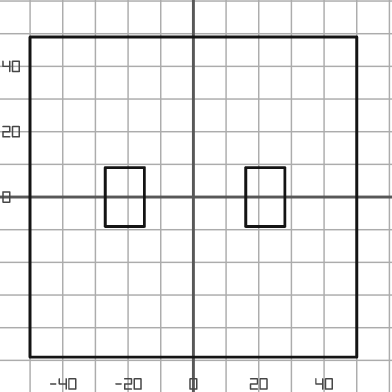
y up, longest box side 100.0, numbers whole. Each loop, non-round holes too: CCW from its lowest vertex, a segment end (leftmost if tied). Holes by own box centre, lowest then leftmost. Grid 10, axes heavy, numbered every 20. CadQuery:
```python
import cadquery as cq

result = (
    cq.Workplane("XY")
    .moveTo(-50.0, -49.0)
    .lineTo(50.0, -49.0)
    .lineTo(50.0, 49.0)
    .lineTo(-50.0, 49.0)
    .close()
    .moveTo(-27.0, -9.0)
    .lineTo(-15.0, -9.0)
    .lineTo(-15.0, 9.0)
    .lineTo(-27.0, 9.0)
    .close()
    .moveTo(16.0, -9.0)
    .lineTo(28.0, -9.0)
    .lineTo(28.0, 9.0)
    .lineTo(16.0, 9.0)
    .close()
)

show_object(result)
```